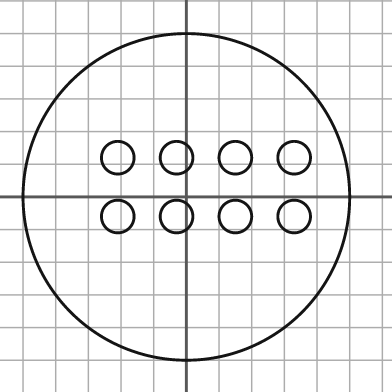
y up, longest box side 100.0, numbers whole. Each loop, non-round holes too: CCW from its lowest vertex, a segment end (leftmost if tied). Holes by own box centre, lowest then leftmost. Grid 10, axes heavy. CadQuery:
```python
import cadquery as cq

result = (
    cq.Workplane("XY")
    .moveTo(0.0, 0.0)
    .circle(50.0)
    .moveTo(-21.0, -6.0)
    .circle(5.0)
    .moveTo(-3.0, -6.0)
    .circle(5.0)
    .moveTo(15.0, -6.0)
    .circle(5.0)
    .moveTo(33.0, -6.0)
    .circle(5.0)
    .moveTo(-21.0, 12.0)
    .circle(5.0)
    .moveTo(-3.0, 12.0)
    .circle(5.0)
    .moveTo(15.0, 12.0)
    .circle(5.0)
    .moveTo(33.0, 12.0)
    .circle(5.0)
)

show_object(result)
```